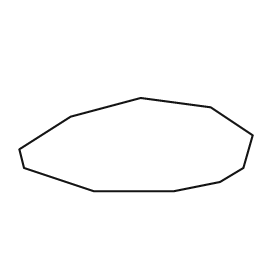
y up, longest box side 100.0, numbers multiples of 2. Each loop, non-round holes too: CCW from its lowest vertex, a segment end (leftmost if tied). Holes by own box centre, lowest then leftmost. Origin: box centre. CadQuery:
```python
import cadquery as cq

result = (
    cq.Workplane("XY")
    .moveTo(-18.0, -20.0)
    .lineTo(16.0, -20.0)
    .lineTo(36.0, -16.0)
    .lineTo(46.0, -10.0)
    .lineTo(50.0, 4.0)
    .lineTo(32.0, 16.0)
    .lineTo(2.0, 20.0)
    .lineTo(-28.0, 12.0)
    .lineTo(-50.0, -2.0)
    .lineTo(-48.0, -10.0)
    .close()
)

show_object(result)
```